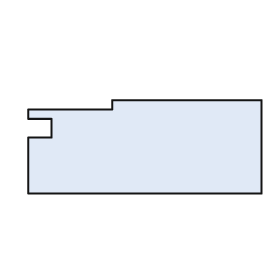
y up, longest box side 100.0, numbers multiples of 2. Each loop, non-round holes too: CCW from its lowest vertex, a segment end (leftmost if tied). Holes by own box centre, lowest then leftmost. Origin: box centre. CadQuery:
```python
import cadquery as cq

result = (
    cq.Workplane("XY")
    .moveTo(-50.0, -20.0)
    .lineTo(50.0, -20.0)
    .lineTo(50.0, 20.0)
    .lineTo(-14.0, 20.0)
    .lineTo(-14.0, 16.0)
    .lineTo(-50.0, 16.0)
    .lineTo(-50.0, 12.0)
    .lineTo(-40.0, 12.0)
    .lineTo(-40.0, 4.0)
    .lineTo(-50.0, 4.0)
    .close()
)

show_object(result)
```